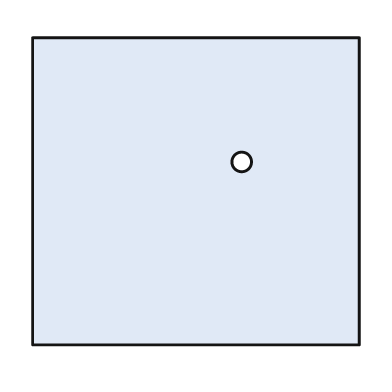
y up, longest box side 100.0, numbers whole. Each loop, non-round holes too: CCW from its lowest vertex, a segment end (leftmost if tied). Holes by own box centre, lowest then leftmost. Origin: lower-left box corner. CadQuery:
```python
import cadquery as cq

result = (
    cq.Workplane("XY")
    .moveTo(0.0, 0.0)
    .lineTo(100.0, 0.0)
    .lineTo(100.0, 94.0)
    .lineTo(0.0, 94.0)
    .close()
    .moveTo(64.0, 56.0)
    .circle(3.0)
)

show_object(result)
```